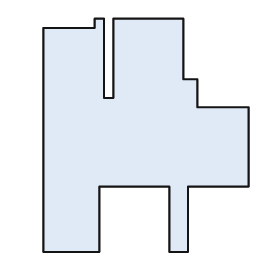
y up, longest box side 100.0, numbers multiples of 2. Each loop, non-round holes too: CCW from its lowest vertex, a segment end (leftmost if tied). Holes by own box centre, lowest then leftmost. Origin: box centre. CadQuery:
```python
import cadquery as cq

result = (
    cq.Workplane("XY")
    .moveTo(-44.0, -50.0)
    .lineTo(-20.0, -50.0)
    .lineTo(-20.0, -22.0)
    .lineTo(10.0, -22.0)
    .lineTo(10.0, -50.0)
    .lineTo(18.0, -50.0)
    .lineTo(18.0, -22.0)
    .lineTo(44.0, -22.0)
    .lineTo(44.0, 12.0)
    .lineTo(22.0, 12.0)
    .lineTo(22.0, 24.0)
    .lineTo(16.0, 24.0)
    .lineTo(16.0, 50.0)
    .lineTo(-14.0, 50.0)
    .lineTo(-14.0, 16.0)
    .lineTo(-18.0, 16.0)
    .lineTo(-18.0, 50.0)
    .lineTo(-22.0, 50.0)
    .lineTo(-22.0, 46.0)
    .lineTo(-44.0, 46.0)
    .close()
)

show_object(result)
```